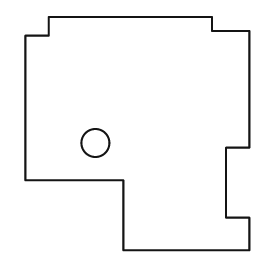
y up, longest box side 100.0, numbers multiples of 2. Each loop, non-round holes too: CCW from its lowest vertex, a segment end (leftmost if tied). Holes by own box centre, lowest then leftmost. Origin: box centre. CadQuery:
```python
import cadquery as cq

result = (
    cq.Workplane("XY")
    .moveTo(-6.0, -50.0)
    .lineTo(48.0, -50.0)
    .lineTo(48.0, -36.0)
    .lineTo(38.0, -36.0)
    .lineTo(38.0, -6.0)
    .lineTo(48.0, -6.0)
    .lineTo(48.0, 44.0)
    .lineTo(32.0, 44.0)
    .lineTo(32.0, 50.0)
    .lineTo(-38.0, 50.0)
    .lineTo(-38.0, 42.0)
    .lineTo(-48.0, 42.0)
    .lineTo(-48.0, -20.0)
    .lineTo(-6.0, -20.0)
    .close()
    .moveTo(-18.0, -4.0)
    .circle(6.0)
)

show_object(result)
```